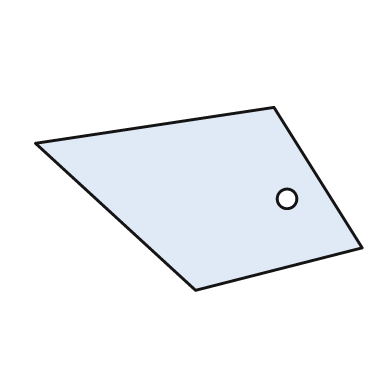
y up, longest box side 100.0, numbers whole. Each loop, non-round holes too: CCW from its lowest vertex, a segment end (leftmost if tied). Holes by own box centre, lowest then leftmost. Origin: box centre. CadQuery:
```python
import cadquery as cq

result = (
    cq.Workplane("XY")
    .moveTo(-1.0, -28.0)
    .lineTo(50.0, -15.0)
    .lineTo(23.0, 28.0)
    .lineTo(-50.0, 17.0)
    .close()
    .moveTo(27.0, 0.0)
    .circle(3.0)
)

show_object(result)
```